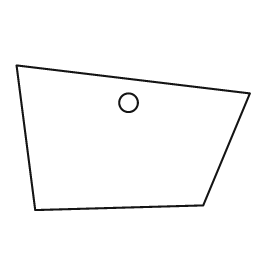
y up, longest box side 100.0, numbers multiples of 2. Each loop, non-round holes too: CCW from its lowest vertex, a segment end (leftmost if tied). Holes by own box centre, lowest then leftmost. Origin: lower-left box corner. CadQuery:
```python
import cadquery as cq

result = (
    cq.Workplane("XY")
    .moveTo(8.0, 0.0)
    .lineTo(80.0, 2.0)
    .lineTo(100.0, 50.0)
    .lineTo(0.0, 62.0)
    .close()
    .moveTo(48.0, 46.0)
    .circle(4.0)
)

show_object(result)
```